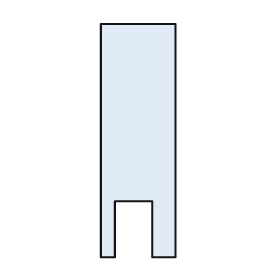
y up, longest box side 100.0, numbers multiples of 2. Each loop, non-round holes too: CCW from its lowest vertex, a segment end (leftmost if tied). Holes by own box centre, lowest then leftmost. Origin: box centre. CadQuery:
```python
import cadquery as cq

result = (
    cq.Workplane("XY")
    .moveTo(-16.0, -50.0)
    .lineTo(-10.0, -50.0)
    .lineTo(-10.0, -26.0)
    .lineTo(6.0, -26.0)
    .lineTo(6.0, -50.0)
    .lineTo(16.0, -50.0)
    .lineTo(16.0, 50.0)
    .lineTo(-16.0, 50.0)
    .close()
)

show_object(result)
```